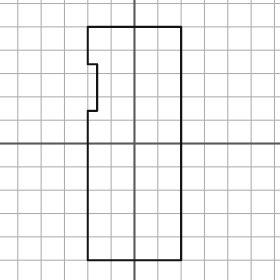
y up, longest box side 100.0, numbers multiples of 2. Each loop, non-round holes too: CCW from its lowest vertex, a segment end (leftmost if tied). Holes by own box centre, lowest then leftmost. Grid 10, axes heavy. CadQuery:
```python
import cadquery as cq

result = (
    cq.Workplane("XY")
    .moveTo(-20.0, -50.0)
    .lineTo(20.0, -50.0)
    .lineTo(20.0, 50.0)
    .lineTo(-20.0, 50.0)
    .lineTo(-20.0, 34.0)
    .lineTo(-16.0, 34.0)
    .lineTo(-16.0, 14.0)
    .lineTo(-20.0, 14.0)
    .close()
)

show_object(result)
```